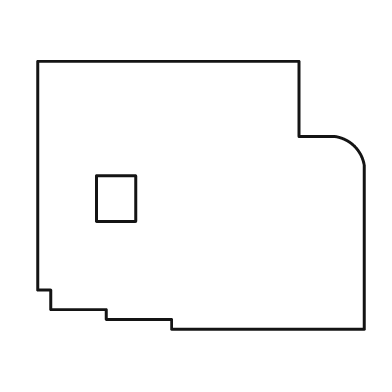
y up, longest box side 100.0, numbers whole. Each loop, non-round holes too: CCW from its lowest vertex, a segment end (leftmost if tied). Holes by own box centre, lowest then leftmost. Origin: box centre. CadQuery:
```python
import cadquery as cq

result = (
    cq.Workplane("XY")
    .moveTo(-9.0, -41.0)
    .lineTo(50.0, -41.0)
    .lineTo(50.0, 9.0)
    .threePointArc((47.0, 15.0), (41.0, 18.0))
    .lineTo(30.0, 18.0)
    .lineTo(30.0, 41.0)
    .lineTo(-50.0, 41.0)
    .lineTo(-50.0, -29.0)
    .lineTo(-46.0, -29.0)
    .lineTo(-46.0, -35.0)
    .lineTo(-29.0, -35.0)
    .lineTo(-29.0, -38.0)
    .lineTo(-9.0, -38.0)
    .close()
    .moveTo(-32.0, -8.0)
    .lineTo(-20.0, -8.0)
    .lineTo(-20.0, 6.0)
    .lineTo(-32.0, 6.0)
    .close()
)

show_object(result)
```